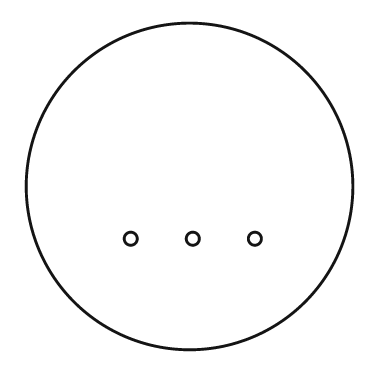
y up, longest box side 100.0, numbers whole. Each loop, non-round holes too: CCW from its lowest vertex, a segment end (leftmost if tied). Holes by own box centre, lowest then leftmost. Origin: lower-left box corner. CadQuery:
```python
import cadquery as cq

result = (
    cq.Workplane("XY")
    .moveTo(50.0, 50.0)
    .circle(50.0)
    .moveTo(32.0, 34.0)
    .circle(2.0)
    .moveTo(51.0, 34.0)
    .circle(2.0)
    .moveTo(70.0, 34.0)
    .circle(2.0)
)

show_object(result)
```